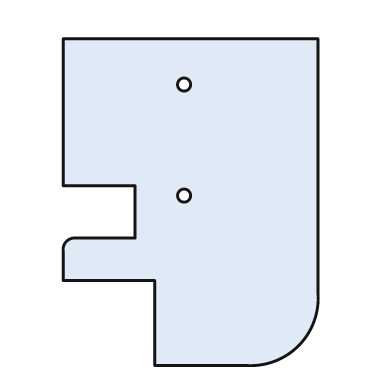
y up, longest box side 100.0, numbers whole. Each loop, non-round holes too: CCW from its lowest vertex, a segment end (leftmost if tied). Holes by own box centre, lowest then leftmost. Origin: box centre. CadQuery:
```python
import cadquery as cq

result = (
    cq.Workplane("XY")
    .moveTo(-11.0, -50.0)
    .lineTo(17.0, -50.0)
    .threePointArc((33.0, -44.0), (39.0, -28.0))
    .lineTo(39.0, 50.0)
    .lineTo(-39.0, 50.0)
    .lineTo(-39.0, 5.0)
    .lineTo(-17.0, 5.0)
    .lineTo(-17.0, -11.0)
    .lineTo(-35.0, -11.0)
    .threePointArc((-38.0, -12.0), (-39.0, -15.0))
    .lineTo(-39.0, -24.0)
    .lineTo(-11.0, -24.0)
    .close()
    .moveTo(-2.0, 2.0)
    .circle(2.0)
    .moveTo(-2.0, 36.0)
    .circle(2.0)
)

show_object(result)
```